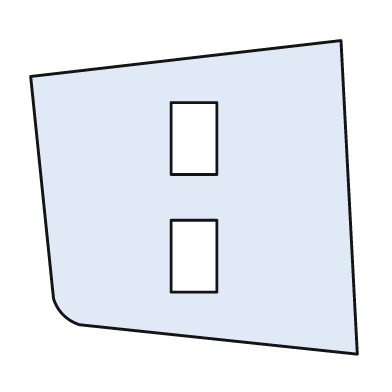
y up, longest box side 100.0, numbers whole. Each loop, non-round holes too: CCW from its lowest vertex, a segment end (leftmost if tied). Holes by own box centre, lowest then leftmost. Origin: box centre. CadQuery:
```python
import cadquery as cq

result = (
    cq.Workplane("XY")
    .moveTo(50.0, -48.0)
    .lineTo(45.0, 48.0)
    .lineTo(-50.0, 37.0)
    .lineTo(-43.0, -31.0)
    .threePointArc((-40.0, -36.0), (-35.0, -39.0))
    .close()
    .moveTo(-7.0, -29.0)
    .lineTo(7.0, -29.0)
    .lineTo(7.0, -7.0)
    .lineTo(-7.0, -7.0)
    .close()
    .moveTo(-7.0, 7.0)
    .lineTo(7.0, 7.0)
    .lineTo(7.0, 29.0)
    .lineTo(-7.0, 29.0)
    .close()
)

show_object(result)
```